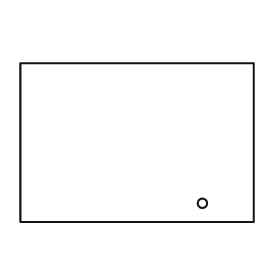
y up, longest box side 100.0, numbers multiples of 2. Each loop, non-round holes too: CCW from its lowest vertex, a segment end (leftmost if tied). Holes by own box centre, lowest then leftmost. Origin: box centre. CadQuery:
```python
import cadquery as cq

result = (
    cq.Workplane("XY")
    .moveTo(-50.0, -34.0)
    .lineTo(50.0, -34.0)
    .lineTo(50.0, 34.0)
    .lineTo(-50.0, 34.0)
    .close()
    .moveTo(28.0, -26.0)
    .circle(2.0)
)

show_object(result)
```